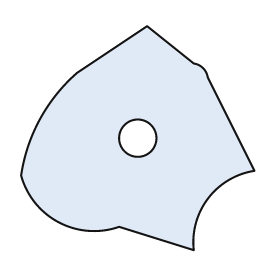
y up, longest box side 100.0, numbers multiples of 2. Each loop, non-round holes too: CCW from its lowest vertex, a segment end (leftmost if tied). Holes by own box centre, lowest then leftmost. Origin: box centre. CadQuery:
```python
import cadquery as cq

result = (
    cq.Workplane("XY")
    .moveTo(24.0, -48.0)
    .threePointArc((30.0, -26.0), (50.0, -14.0))
    .lineTo(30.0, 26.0)
    .threePointArc((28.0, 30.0), (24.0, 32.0))
    .lineTo(4.0, 48.0)
    .lineTo(-26.0, 28.0)
    .threePointArc((-42.0, 8.0), (-50.0, -16.0))
    .threePointArc((-34.0, -36.0), (-8.0, -38.0))
    .close()
    .moveTo(0.0, 0.0)
    .circle(8.0)
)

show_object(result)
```